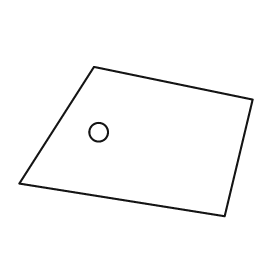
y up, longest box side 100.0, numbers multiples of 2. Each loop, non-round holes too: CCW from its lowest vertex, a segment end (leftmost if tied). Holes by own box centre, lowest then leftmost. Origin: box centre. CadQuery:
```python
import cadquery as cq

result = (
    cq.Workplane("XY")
    .moveTo(38.0, -32.0)
    .lineTo(50.0, 18.0)
    .lineTo(-18.0, 32.0)
    .lineTo(-50.0, -18.0)
    .close()
    .moveTo(-16.0, 4.0)
    .circle(4.0)
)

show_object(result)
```